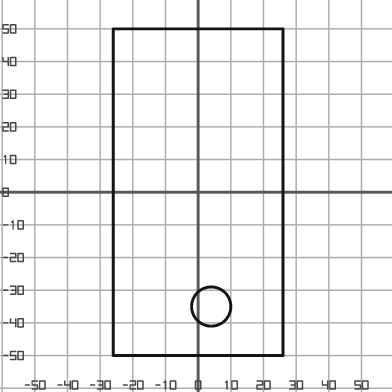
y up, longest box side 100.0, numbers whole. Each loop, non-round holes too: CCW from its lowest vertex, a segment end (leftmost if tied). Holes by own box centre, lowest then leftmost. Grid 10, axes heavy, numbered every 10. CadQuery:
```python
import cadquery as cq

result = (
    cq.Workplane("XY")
    .moveTo(-26.0, -50.0)
    .lineTo(26.0, -50.0)
    .lineTo(26.0, 50.0)
    .lineTo(-26.0, 50.0)
    .close()
    .moveTo(4.0, -35.0)
    .circle(6.0)
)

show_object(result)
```